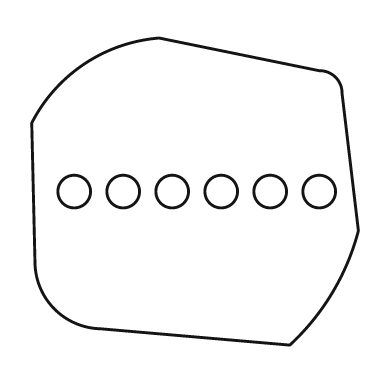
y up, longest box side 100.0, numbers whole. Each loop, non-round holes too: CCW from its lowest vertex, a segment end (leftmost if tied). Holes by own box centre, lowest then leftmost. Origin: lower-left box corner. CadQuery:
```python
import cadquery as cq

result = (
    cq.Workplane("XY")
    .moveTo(79.0, 0.0)
    .threePointArc((92.0, 16.0), (100.0, 35.0))
    .lineTo(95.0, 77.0)
    .threePointArc((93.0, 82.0), (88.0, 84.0))
    .lineTo(39.0, 94.0)
    .threePointArc((16.0, 86.0), (0.0, 68.0))
    .lineTo(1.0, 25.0)
    .threePointArc((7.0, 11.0), (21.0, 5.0))
    .close()
    .moveTo(13.0, 47.0)
    .circle(5.0)
    .moveTo(28.0, 47.0)
    .circle(5.0)
    .moveTo(43.0, 47.0)
    .circle(5.0)
    .moveTo(58.0, 47.0)
    .circle(5.0)
    .moveTo(73.0, 47.0)
    .circle(5.0)
    .moveTo(88.0, 47.0)
    .circle(5.0)
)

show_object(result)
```